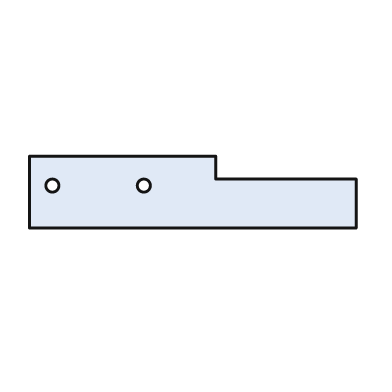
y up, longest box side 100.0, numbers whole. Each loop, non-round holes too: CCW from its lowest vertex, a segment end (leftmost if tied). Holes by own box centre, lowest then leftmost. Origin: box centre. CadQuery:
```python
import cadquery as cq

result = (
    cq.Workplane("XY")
    .moveTo(-50.0, -11.0)
    .lineTo(50.0, -11.0)
    .lineTo(50.0, 4.0)
    .lineTo(7.0, 4.0)
    .lineTo(7.0, 11.0)
    .lineTo(-50.0, 11.0)
    .close()
    .moveTo(-43.0, 2.0)
    .circle(2.0)
    .moveTo(-15.0, 2.0)
    .circle(2.0)
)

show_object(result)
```